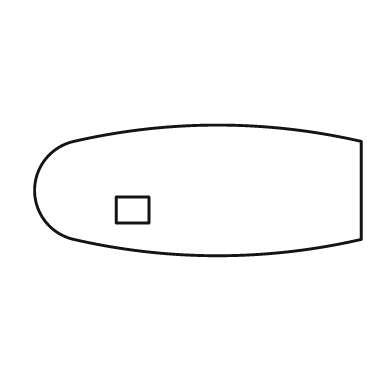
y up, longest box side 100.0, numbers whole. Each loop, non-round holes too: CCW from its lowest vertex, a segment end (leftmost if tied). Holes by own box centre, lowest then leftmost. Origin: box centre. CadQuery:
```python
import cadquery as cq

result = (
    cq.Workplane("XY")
    .moveTo(-38.0, -15.0)
    .threePointArc((6.0, -20.0), (50.0, -15.0))
    .lineTo(50.0, 15.0)
    .threePointArc((6.0, 20.0), (-38.0, 15.0))
    .threePointArc((-50.0, 0.0), (-38.0, -15.0))
    .close()
    .moveTo(-25.0, -10.0)
    .lineTo(-15.0, -10.0)
    .lineTo(-15.0, -2.0)
    .lineTo(-25.0, -2.0)
    .close()
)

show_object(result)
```